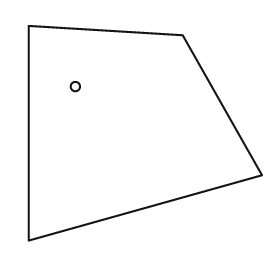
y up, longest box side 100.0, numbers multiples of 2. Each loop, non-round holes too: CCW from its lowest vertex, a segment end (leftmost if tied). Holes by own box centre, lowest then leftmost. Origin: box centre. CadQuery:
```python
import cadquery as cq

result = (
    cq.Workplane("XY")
    .moveTo(-50.0, -46.0)
    .lineTo(50.0, -18.0)
    .lineTo(16.0, 42.0)
    .lineTo(-50.0, 46.0)
    .close()
    .moveTo(-30.0, 20.0)
    .circle(2.0)
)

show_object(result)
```